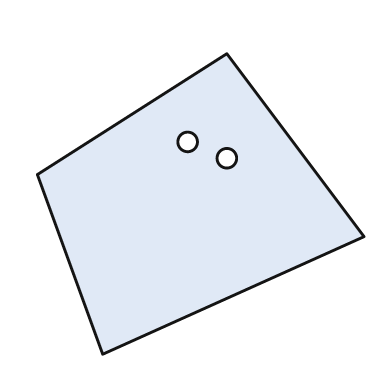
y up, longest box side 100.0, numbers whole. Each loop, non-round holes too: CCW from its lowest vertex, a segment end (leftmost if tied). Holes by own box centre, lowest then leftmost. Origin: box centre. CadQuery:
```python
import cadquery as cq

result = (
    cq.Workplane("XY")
    .moveTo(-30.0, -46.0)
    .lineTo(50.0, -10.0)
    .lineTo(8.0, 46.0)
    .lineTo(-50.0, 9.0)
    .close()
    .moveTo(8.0, 14.0)
    .circle(3.0)
    .moveTo(-4.0, 19.0)
    .circle(3.0)
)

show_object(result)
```